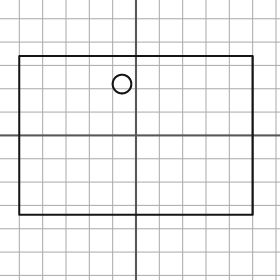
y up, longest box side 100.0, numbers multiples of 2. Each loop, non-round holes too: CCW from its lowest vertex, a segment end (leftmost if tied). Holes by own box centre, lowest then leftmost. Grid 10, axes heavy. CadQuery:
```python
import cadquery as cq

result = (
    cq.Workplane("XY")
    .moveTo(-50.0, -34.0)
    .lineTo(50.0, -34.0)
    .lineTo(50.0, 34.0)
    .lineTo(-50.0, 34.0)
    .close()
    .moveTo(-6.0, 22.0)
    .circle(4.0)
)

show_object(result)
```